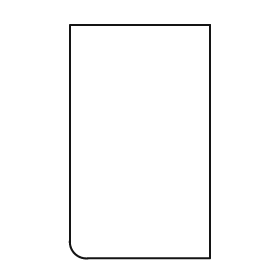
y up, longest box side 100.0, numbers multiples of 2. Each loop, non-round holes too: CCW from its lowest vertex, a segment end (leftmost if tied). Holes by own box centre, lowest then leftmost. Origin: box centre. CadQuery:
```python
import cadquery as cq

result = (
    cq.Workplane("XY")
    .moveTo(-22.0, -50.0)
    .lineTo(30.0, -50.0)
    .lineTo(30.0, 50.0)
    .lineTo(-30.0, 50.0)
    .lineTo(-30.0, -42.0)
    .threePointArc((-28.0, -48.0), (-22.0, -50.0))
    .close()
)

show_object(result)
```